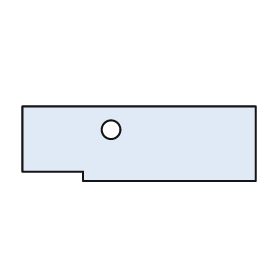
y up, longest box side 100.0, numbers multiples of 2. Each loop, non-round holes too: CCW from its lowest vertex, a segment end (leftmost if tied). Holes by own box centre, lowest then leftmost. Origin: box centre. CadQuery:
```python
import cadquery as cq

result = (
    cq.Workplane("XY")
    .moveTo(-24.0, -16.0)
    .lineTo(50.0, -16.0)
    .lineTo(50.0, 16.0)
    .lineTo(-50.0, 16.0)
    .lineTo(-50.0, -12.0)
    .lineTo(-24.0, -12.0)
    .close()
    .moveTo(-12.0, 6.0)
    .circle(4.0)
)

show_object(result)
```